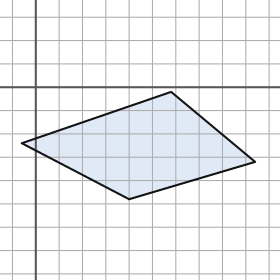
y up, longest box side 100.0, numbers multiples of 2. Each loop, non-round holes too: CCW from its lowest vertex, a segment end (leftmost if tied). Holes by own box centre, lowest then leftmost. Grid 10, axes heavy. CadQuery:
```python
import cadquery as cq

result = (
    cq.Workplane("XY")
    .moveTo(40.0, -48.0)
    .lineTo(94.0, -32.0)
    .lineTo(58.0, -2.0)
    .lineTo(-6.0, -24.0)
    .close()
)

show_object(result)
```